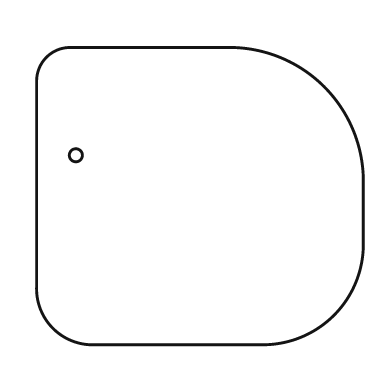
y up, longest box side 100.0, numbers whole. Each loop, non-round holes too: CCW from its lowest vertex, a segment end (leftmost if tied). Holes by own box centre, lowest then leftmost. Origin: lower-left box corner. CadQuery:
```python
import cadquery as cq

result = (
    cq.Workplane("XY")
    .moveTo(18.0, 0.0)
    .lineTo(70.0, 0.0)
    .threePointArc((91.0, 9.0), (100.0, 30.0))
    .lineTo(100.0, 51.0)
    .threePointArc((88.0, 79.0), (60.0, 91.0))
    .lineTo(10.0, 91.0)
    .threePointArc((3.0, 88.0), (0.0, 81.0))
    .lineTo(0.0, 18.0)
    .threePointArc((5.0, 5.0), (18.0, 0.0))
    .close()
    .moveTo(12.0, 58.0)
    .circle(2.0)
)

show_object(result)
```